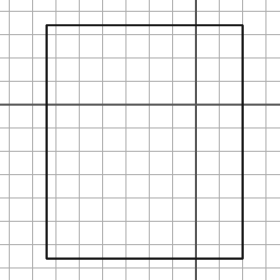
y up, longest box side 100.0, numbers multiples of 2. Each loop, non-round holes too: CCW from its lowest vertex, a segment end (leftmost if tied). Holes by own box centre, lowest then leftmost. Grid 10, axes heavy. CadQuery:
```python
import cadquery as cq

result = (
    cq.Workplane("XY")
    .moveTo(-64.0, -66.0)
    .lineTo(20.0, -66.0)
    .lineTo(20.0, 34.0)
    .lineTo(-64.0, 34.0)
    .close()
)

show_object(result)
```